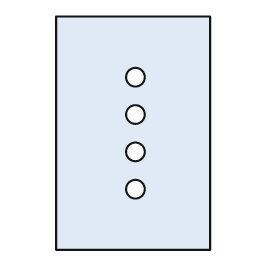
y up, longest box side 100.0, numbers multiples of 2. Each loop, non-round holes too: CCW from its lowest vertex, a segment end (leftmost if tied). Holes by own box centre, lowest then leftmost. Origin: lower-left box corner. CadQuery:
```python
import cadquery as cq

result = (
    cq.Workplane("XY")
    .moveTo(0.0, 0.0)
    .lineTo(66.0, 0.0)
    .lineTo(66.0, 100.0)
    .lineTo(0.0, 100.0)
    .close()
    .moveTo(34.0, 26.0)
    .circle(4.0)
    .moveTo(34.0, 42.0)
    .circle(4.0)
    .moveTo(34.0, 58.0)
    .circle(4.0)
    .moveTo(34.0, 74.0)
    .circle(4.0)
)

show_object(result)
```